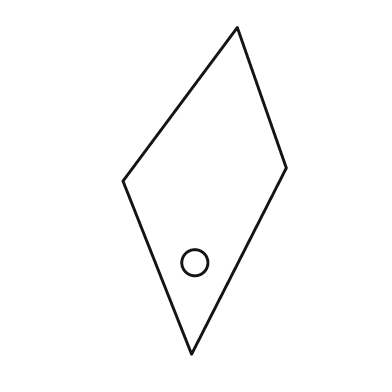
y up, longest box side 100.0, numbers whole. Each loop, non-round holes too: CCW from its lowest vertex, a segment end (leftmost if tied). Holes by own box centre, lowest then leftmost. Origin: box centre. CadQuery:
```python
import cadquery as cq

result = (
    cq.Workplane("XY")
    .moveTo(-4.0, -50.0)
    .lineTo(25.0, 7.0)
    .lineTo(10.0, 50.0)
    .lineTo(-25.0, 3.0)
    .close()
    .moveTo(-3.0, -22.0)
    .circle(4.0)
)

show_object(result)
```